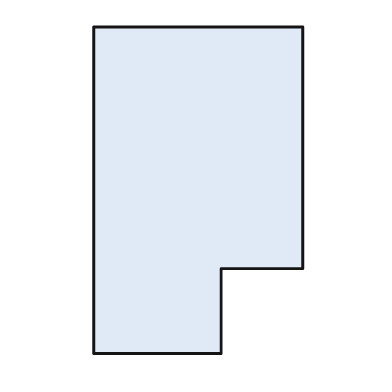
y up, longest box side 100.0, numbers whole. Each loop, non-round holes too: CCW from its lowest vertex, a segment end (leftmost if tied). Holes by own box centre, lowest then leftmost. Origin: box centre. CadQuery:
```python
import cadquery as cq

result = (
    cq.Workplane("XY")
    .moveTo(-32.0, -50.0)
    .lineTo(7.0, -50.0)
    .lineTo(7.0, -24.0)
    .lineTo(32.0, -24.0)
    .lineTo(32.0, 50.0)
    .lineTo(-32.0, 50.0)
    .close()
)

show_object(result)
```